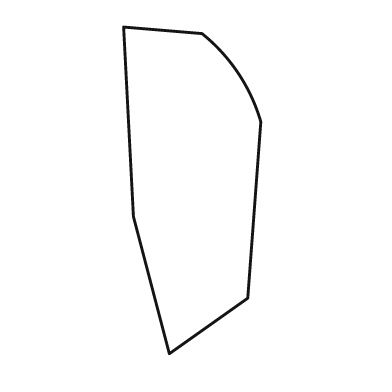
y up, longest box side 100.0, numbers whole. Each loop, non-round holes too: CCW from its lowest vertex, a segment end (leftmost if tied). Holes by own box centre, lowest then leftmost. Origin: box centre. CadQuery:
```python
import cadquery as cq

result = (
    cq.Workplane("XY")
    .moveTo(-7.0, -50.0)
    .lineTo(17.0, -33.0)
    .lineTo(21.0, 21.0)
    .threePointArc((14.0, 36.0), (3.0, 48.0))
    .lineTo(-21.0, 50.0)
    .lineTo(-18.0, -8.0)
    .close()
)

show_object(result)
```